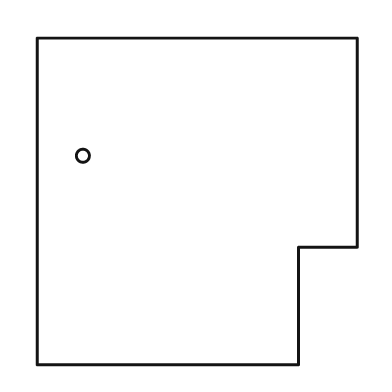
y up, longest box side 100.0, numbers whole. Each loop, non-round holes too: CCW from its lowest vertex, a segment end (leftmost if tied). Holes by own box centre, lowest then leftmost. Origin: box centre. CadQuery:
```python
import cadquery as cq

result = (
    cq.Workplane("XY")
    .moveTo(-49.0, -50.0)
    .lineTo(31.0, -50.0)
    .lineTo(31.0, -14.0)
    .lineTo(49.0, -14.0)
    .lineTo(49.0, 50.0)
    .lineTo(-49.0, 50.0)
    .close()
    .moveTo(-35.0, 14.0)
    .circle(2.0)
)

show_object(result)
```